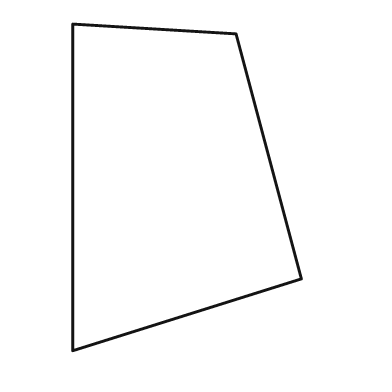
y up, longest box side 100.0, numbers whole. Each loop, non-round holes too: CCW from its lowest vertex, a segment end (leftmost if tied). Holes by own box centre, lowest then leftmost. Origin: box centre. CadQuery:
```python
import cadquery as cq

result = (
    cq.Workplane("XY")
    .moveTo(-35.0, -50.0)
    .lineTo(35.0, -28.0)
    .lineTo(15.0, 47.0)
    .lineTo(-35.0, 50.0)
    .close()
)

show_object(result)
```